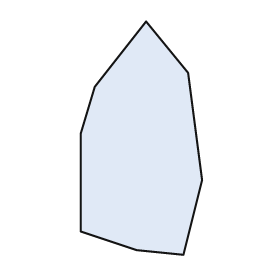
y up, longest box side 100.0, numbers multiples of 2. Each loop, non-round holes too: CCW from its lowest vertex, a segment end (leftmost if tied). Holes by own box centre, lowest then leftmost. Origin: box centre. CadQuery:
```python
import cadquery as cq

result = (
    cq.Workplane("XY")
    .moveTo(18.0, -50.0)
    .lineTo(26.0, -18.0)
    .lineTo(20.0, 28.0)
    .lineTo(2.0, 50.0)
    .lineTo(-20.0, 22.0)
    .lineTo(-26.0, 2.0)
    .lineTo(-26.0, -40.0)
    .lineTo(-2.0, -48.0)
    .close()
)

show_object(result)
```